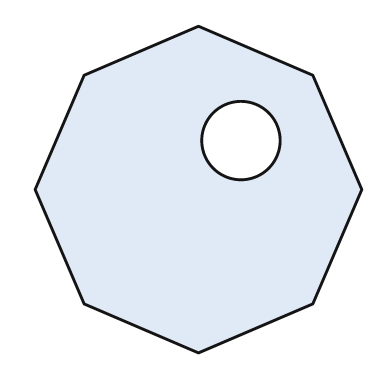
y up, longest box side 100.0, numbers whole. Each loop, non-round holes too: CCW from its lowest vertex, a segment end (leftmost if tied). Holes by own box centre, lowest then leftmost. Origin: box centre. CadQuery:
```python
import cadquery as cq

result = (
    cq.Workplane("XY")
    .moveTo(0.0, -50.0)
    .lineTo(35.0, -35.0)
    .lineTo(50.0, 0.0)
    .lineTo(35.0, 35.0)
    .lineTo(0.0, 50.0)
    .lineTo(-35.0, 35.0)
    .lineTo(-50.0, 0.0)
    .lineTo(-35.0, -35.0)
    .close()
    .moveTo(13.0, 15.0)
    .circle(12.0)
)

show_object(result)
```